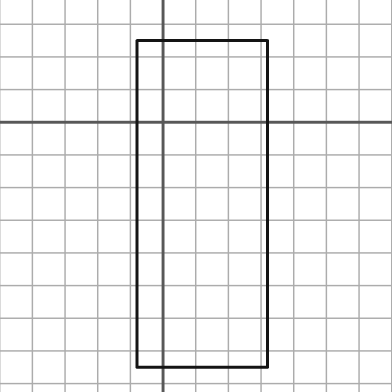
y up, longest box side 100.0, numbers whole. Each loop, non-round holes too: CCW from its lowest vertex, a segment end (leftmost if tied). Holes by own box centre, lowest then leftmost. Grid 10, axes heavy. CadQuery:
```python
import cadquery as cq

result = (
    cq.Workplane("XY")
    .moveTo(-8.0, -75.0)
    .lineTo(32.0, -75.0)
    .lineTo(32.0, 25.0)
    .lineTo(-8.0, 25.0)
    .close()
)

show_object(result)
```